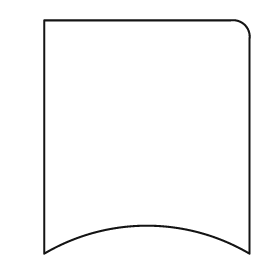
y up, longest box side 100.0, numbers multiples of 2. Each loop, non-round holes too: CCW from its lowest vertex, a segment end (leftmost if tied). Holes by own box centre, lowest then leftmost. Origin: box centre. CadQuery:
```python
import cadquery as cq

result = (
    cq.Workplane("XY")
    .moveTo(-44.0, -50.0)
    .threePointArc((0.0, -38.0), (44.0, -50.0))
    .lineTo(44.0, 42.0)
    .threePointArc((42.0, 48.0), (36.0, 50.0))
    .lineTo(-44.0, 50.0)
    .close()
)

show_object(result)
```